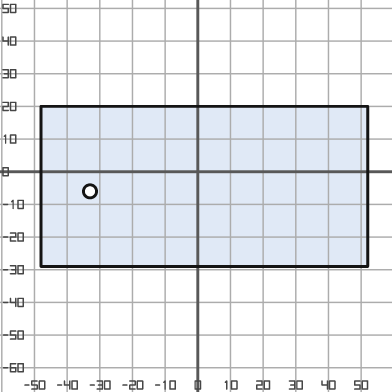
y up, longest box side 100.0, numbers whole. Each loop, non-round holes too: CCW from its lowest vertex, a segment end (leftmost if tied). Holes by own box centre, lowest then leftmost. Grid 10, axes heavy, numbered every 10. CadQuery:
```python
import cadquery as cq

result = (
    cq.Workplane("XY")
    .moveTo(-48.0, -29.0)
    .lineTo(52.0, -29.0)
    .lineTo(52.0, 20.0)
    .lineTo(-48.0, 20.0)
    .close()
    .moveTo(-33.0, -6.0)
    .circle(2.0)
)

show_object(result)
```